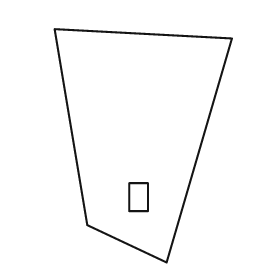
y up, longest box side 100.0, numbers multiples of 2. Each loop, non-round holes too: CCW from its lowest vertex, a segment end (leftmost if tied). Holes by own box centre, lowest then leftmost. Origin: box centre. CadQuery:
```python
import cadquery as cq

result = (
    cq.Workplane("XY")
    .moveTo(10.0, -50.0)
    .lineTo(38.0, 46.0)
    .lineTo(-38.0, 50.0)
    .lineTo(-24.0, -34.0)
    .close()
    .moveTo(-6.0, -28.0)
    .lineTo(2.0, -28.0)
    .lineTo(2.0, -16.0)
    .lineTo(-6.0, -16.0)
    .close()
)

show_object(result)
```